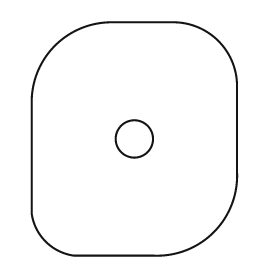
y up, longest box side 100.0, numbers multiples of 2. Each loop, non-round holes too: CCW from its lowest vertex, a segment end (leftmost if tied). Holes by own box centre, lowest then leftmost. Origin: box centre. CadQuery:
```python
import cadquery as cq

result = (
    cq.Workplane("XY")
    .moveTo(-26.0, -50.0)
    .lineTo(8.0, -50.0)
    .threePointArc((34.0, -40.0), (44.0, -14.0))
    .lineTo(44.0, 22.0)
    .threePointArc((36.0, 42.0), (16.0, 50.0))
    .lineTo(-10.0, 50.0)
    .threePointArc((-34.0, 40.0), (-44.0, 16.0))
    .lineTo(-44.0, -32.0)
    .threePointArc((-38.0, -44.0), (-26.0, -50.0))
    .close()
    .moveTo(0.0, 0.0)
    .circle(8.0)
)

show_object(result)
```